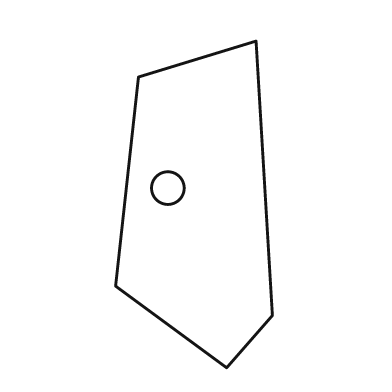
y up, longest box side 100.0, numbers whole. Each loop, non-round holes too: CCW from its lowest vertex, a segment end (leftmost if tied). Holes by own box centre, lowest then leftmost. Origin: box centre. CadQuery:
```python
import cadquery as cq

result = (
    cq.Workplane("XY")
    .moveTo(10.0, -50.0)
    .lineTo(24.0, -34.0)
    .lineTo(19.0, 50.0)
    .lineTo(-17.0, 39.0)
    .lineTo(-24.0, -25.0)
    .close()
    .moveTo(-8.0, 5.0)
    .circle(5.0)
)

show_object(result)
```